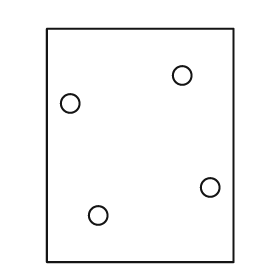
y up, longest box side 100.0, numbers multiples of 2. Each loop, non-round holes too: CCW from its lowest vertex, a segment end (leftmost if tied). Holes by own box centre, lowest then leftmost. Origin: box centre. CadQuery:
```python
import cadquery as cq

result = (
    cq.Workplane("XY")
    .moveTo(-40.0, -50.0)
    .lineTo(40.0, -50.0)
    .lineTo(40.0, 50.0)
    .lineTo(-40.0, 50.0)
    .close()
    .moveTo(-18.0, -30.0)
    .circle(4.0)
    .moveTo(30.0, -18.0)
    .circle(4.0)
    .moveTo(-30.0, 18.0)
    .circle(4.0)
    .moveTo(18.0, 30.0)
    .circle(4.0)
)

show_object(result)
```